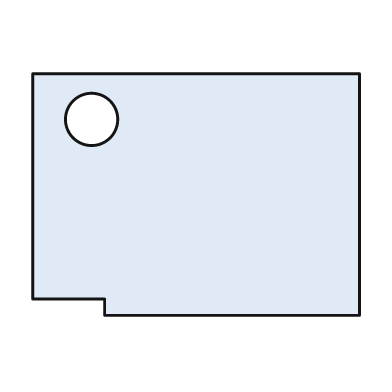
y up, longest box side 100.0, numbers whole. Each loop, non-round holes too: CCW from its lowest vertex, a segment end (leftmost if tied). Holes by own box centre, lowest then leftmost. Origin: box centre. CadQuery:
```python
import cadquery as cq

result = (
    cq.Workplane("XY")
    .moveTo(-28.0, -37.0)
    .lineTo(50.0, -37.0)
    .lineTo(50.0, 37.0)
    .lineTo(-50.0, 37.0)
    .lineTo(-50.0, -32.0)
    .lineTo(-28.0, -32.0)
    .close()
    .moveTo(-32.0, 23.0)
    .circle(8.0)
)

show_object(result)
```